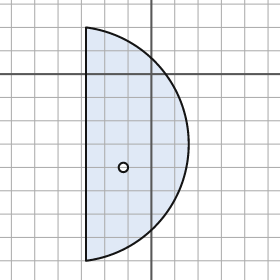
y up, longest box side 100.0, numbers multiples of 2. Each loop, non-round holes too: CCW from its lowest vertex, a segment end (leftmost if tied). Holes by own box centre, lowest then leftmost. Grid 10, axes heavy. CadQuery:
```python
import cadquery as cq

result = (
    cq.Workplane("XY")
    .moveTo(-28.0, -80.0)
    .threePointArc((16.0, -30.0), (-28.0, 20.0))
    .close()
    .moveTo(-12.0, -40.0)
    .circle(2.0)
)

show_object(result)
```